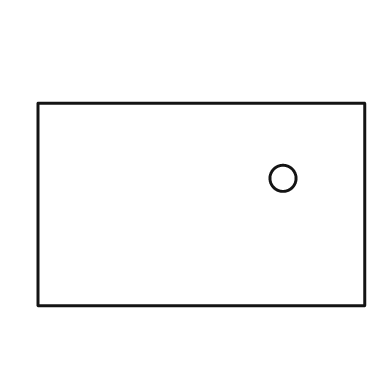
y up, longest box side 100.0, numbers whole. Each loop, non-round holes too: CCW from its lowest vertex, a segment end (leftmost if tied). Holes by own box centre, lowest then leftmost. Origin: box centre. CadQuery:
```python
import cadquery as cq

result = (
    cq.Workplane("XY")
    .moveTo(-50.0, -31.0)
    .lineTo(50.0, -31.0)
    .lineTo(50.0, 31.0)
    .lineTo(-50.0, 31.0)
    .close()
    .moveTo(25.0, 8.0)
    .circle(4.0)
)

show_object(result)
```